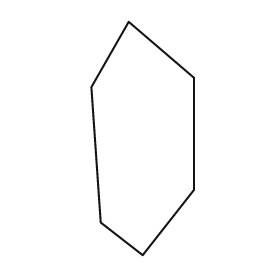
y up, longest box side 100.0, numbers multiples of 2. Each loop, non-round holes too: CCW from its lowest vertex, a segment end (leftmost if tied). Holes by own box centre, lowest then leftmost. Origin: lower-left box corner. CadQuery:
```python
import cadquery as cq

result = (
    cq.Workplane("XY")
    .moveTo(22.0, 0.0)
    .lineTo(44.0, 28.0)
    .lineTo(44.0, 76.0)
    .lineTo(16.0, 100.0)
    .lineTo(0.0, 72.0)
    .lineTo(4.0, 14.0)
    .close()
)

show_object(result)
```